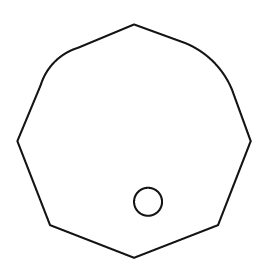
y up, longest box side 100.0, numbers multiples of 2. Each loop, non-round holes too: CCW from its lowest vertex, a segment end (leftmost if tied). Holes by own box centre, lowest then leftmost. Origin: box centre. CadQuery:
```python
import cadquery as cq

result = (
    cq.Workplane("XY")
    .moveTo(0.0, -50.0)
    .lineTo(36.0, -36.0)
    .lineTo(50.0, 0.0)
    .lineTo(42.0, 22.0)
    .threePointArc((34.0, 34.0), (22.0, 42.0))
    .lineTo(0.0, 50.0)
    .lineTo(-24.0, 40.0)
    .threePointArc((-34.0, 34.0), (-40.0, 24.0))
    .lineTo(-50.0, 0.0)
    .lineTo(-36.0, -36.0)
    .close()
    .moveTo(6.0, -26.0)
    .circle(6.0)
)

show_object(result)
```